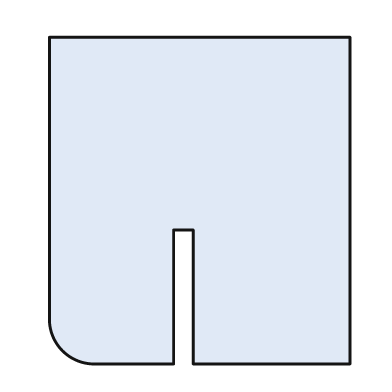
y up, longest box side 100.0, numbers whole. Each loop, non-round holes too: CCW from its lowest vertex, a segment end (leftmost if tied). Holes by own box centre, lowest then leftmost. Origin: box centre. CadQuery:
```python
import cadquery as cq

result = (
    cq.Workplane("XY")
    .moveTo(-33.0, -50.0)
    .lineTo(-8.0, -50.0)
    .lineTo(-8.0, -9.0)
    .lineTo(-2.0, -9.0)
    .lineTo(-2.0, -50.0)
    .lineTo(46.0, -50.0)
    .lineTo(46.0, 50.0)
    .lineTo(-46.0, 50.0)
    .lineTo(-46.0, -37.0)
    .threePointArc((-42.0, -46.0), (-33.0, -50.0))
    .close()
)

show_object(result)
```